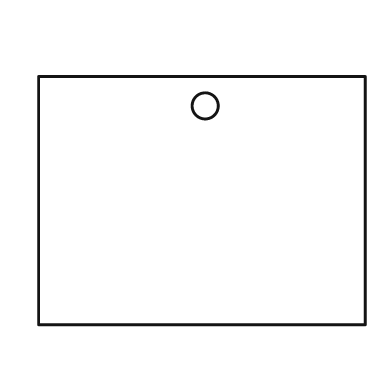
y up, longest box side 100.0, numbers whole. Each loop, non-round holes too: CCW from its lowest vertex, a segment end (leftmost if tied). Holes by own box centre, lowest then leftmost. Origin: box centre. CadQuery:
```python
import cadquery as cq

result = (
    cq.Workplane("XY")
    .moveTo(-50.0, -38.0)
    .lineTo(50.0, -38.0)
    .lineTo(50.0, 38.0)
    .lineTo(-50.0, 38.0)
    .close()
    .moveTo(1.0, 29.0)
    .circle(4.0)
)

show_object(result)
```